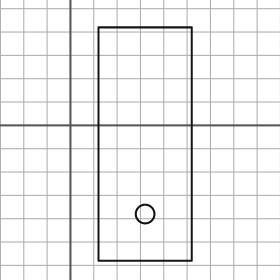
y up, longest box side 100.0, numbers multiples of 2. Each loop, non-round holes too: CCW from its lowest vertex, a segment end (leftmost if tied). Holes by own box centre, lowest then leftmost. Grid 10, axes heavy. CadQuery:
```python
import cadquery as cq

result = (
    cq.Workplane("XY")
    .moveTo(12.0, -58.0)
    .lineTo(52.0, -58.0)
    .lineTo(52.0, 42.0)
    .lineTo(12.0, 42.0)
    .close()
    .moveTo(32.0, -38.0)
    .circle(4.0)
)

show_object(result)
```